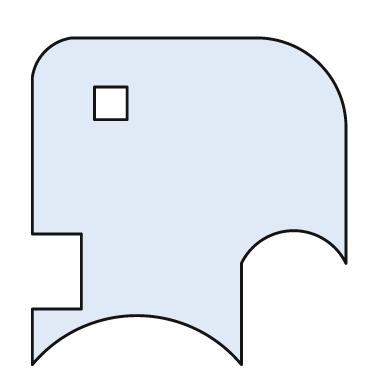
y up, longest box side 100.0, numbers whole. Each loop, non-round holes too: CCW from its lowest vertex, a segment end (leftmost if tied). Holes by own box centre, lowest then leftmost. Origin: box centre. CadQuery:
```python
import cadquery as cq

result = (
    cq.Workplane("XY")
    .moveTo(-48.0, -50.0)
    .threePointArc((-16.0, -35.0), (16.0, -50.0))
    .lineTo(16.0, -19.0)
    .threePointArc((32.0, -9.0), (48.0, -19.0))
    .lineTo(48.0, 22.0)
    .threePointArc((40.0, 42.0), (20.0, 50.0))
    .lineTo(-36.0, 50.0)
    .threePointArc((-44.0, 46.0), (-48.0, 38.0))
    .lineTo(-48.0, -10.0)
    .lineTo(-33.0, -10.0)
    .lineTo(-33.0, -33.0)
    .lineTo(-48.0, -33.0)
    .close()
    .moveTo(-29.0, 25.0)
    .lineTo(-19.0, 25.0)
    .lineTo(-19.0, 35.0)
    .lineTo(-29.0, 35.0)
    .close()
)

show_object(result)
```